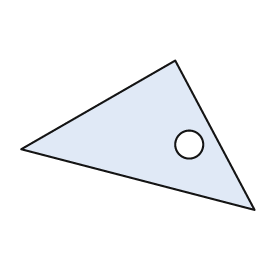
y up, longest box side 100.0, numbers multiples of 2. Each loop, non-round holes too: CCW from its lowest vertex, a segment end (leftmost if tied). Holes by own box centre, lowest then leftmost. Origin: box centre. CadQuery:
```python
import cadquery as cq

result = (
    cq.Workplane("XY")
    .moveTo(50.0, -32.0)
    .lineTo(16.0, 32.0)
    .lineTo(-50.0, -6.0)
    .close()
    .moveTo(22.0, -4.0)
    .circle(6.0)
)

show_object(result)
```